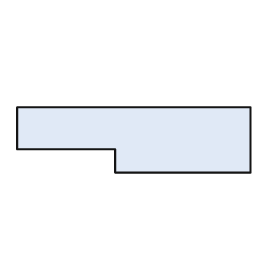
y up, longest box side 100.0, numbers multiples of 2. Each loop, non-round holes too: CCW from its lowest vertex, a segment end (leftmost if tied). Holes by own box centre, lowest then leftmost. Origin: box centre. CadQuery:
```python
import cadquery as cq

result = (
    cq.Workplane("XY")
    .moveTo(-8.0, -14.0)
    .lineTo(50.0, -14.0)
    .lineTo(50.0, 14.0)
    .lineTo(-50.0, 14.0)
    .lineTo(-50.0, -4.0)
    .lineTo(-8.0, -4.0)
    .close()
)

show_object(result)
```